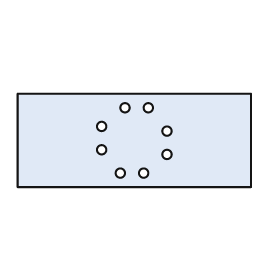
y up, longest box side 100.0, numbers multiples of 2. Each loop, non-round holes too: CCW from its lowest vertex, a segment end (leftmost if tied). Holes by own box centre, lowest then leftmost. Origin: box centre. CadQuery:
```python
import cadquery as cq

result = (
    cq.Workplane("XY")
    .moveTo(-50.0, -20.0)
    .lineTo(50.0, -20.0)
    .lineTo(50.0, 20.0)
    .lineTo(-50.0, 20.0)
    .close()
    .moveTo(-6.0, -14.0)
    .circle(2.0)
    .moveTo(4.0, -14.0)
    .circle(2.0)
    .moveTo(14.0, -6.0)
    .circle(2.0)
    .moveTo(-14.0, -4.0)
    .circle(2.0)
    .moveTo(14.0, 4.0)
    .circle(2.0)
    .moveTo(-14.0, 6.0)
    .circle(2.0)
    .moveTo(-4.0, 14.0)
    .circle(2.0)
    .moveTo(6.0, 14.0)
    .circle(2.0)
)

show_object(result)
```